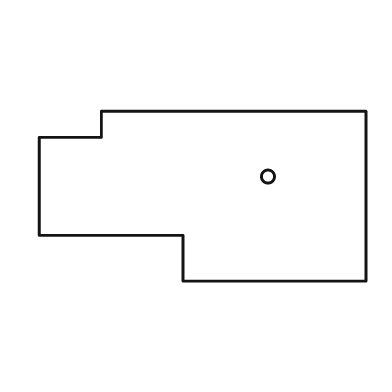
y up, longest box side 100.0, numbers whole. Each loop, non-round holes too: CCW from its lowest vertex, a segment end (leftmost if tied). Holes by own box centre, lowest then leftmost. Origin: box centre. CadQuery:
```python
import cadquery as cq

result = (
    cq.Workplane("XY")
    .moveTo(-6.0, -26.0)
    .lineTo(50.0, -26.0)
    .lineTo(50.0, 26.0)
    .lineTo(-31.0, 26.0)
    .lineTo(-31.0, 18.0)
    .lineTo(-50.0, 18.0)
    .lineTo(-50.0, -12.0)
    .lineTo(-6.0, -12.0)
    .close()
    .moveTo(20.0, 6.0)
    .circle(2.0)
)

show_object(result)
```